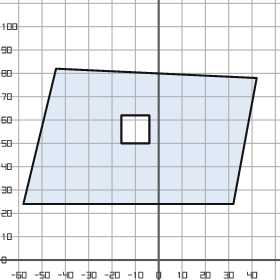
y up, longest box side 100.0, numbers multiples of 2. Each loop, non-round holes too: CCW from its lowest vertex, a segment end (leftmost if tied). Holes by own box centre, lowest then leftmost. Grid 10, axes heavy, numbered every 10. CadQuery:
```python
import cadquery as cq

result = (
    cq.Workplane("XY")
    .moveTo(-58.0, 24.0)
    .lineTo(32.0, 24.0)
    .lineTo(42.0, 78.0)
    .lineTo(-44.0, 82.0)
    .close()
    .moveTo(-16.0, 50.0)
    .lineTo(-4.0, 50.0)
    .lineTo(-4.0, 62.0)
    .lineTo(-16.0, 62.0)
    .close()
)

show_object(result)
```